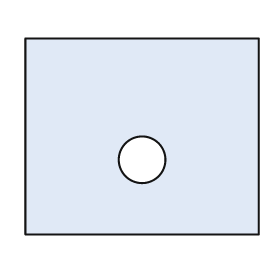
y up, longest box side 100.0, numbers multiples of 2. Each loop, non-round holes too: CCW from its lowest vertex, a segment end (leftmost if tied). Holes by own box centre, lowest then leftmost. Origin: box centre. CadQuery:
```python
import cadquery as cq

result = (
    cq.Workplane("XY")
    .moveTo(-50.0, -42.0)
    .lineTo(50.0, -42.0)
    .lineTo(50.0, 42.0)
    .lineTo(-50.0, 42.0)
    .close()
    .moveTo(0.0, -10.0)
    .circle(10.0)
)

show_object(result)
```